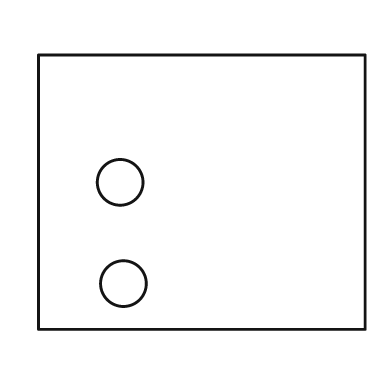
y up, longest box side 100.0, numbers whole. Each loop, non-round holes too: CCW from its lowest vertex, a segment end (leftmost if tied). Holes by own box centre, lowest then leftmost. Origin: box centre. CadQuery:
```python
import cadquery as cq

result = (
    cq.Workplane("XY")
    .moveTo(-50.0, -42.0)
    .lineTo(50.0, -42.0)
    .lineTo(50.0, 42.0)
    .lineTo(-50.0, 42.0)
    .close()
    .moveTo(-24.0, -28.0)
    .circle(7.0)
    .moveTo(-25.0, 3.0)
    .circle(7.0)
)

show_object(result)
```